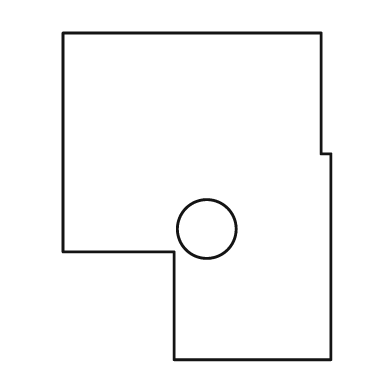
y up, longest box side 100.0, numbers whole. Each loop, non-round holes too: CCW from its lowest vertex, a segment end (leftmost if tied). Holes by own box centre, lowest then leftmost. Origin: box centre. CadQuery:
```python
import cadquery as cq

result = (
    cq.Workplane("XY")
    .moveTo(-7.0, -50.0)
    .lineTo(41.0, -50.0)
    .lineTo(41.0, 13.0)
    .lineTo(38.0, 13.0)
    .lineTo(38.0, 50.0)
    .lineTo(-41.0, 50.0)
    .lineTo(-41.0, -17.0)
    .lineTo(-7.0, -17.0)
    .close()
    .moveTo(3.0, -10.0)
    .circle(9.0)
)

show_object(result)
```